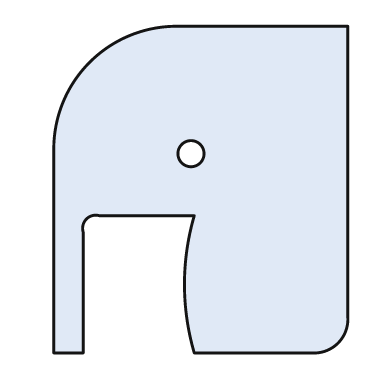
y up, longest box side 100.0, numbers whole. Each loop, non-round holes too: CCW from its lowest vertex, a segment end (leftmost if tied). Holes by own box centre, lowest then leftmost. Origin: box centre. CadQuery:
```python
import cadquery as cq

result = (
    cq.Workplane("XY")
    .moveTo(-45.0, -50.0)
    .lineTo(-36.0, -50.0)
    .lineTo(-36.0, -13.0)
    .threePointArc((-35.0, -9.0), (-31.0, -8.0))
    .lineTo(-2.0, -8.0)
    .threePointArc((-5.0, -29.0), (-2.0, -50.0))
    .lineTo(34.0, -50.0)
    .threePointArc((42.0, -47.0), (45.0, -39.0))
    .lineTo(45.0, 50.0)
    .lineTo(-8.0, 50.0)
    .threePointArc((-34.0, 39.0), (-45.0, 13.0))
    .close()
    .moveTo(-3.0, 11.0)
    .circle(4.0)
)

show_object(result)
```